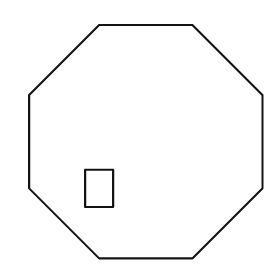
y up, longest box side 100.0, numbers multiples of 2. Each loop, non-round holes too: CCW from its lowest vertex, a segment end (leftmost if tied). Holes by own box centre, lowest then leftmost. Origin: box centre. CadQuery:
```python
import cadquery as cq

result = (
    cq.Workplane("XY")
    .moveTo(-20.0, -50.0)
    .lineTo(20.0, -50.0)
    .lineTo(50.0, -20.0)
    .lineTo(50.0, 20.0)
    .lineTo(20.0, 50.0)
    .lineTo(-20.0, 50.0)
    .lineTo(-50.0, 20.0)
    .lineTo(-50.0, -20.0)
    .close()
    .moveTo(-26.0, -28.0)
    .lineTo(-14.0, -28.0)
    .lineTo(-14.0, -12.0)
    .lineTo(-26.0, -12.0)
    .close()
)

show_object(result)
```